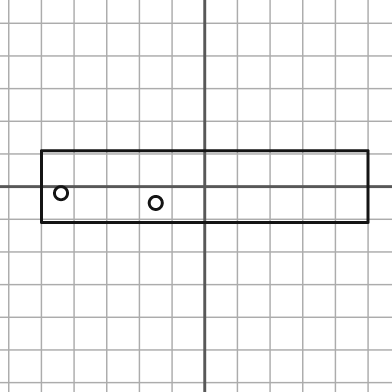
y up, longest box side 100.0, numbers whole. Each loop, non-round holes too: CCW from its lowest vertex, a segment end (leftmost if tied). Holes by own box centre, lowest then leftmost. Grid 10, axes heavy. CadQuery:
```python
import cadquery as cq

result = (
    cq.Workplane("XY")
    .moveTo(-50.0, -11.0)
    .lineTo(50.0, -11.0)
    .lineTo(50.0, 11.0)
    .lineTo(-50.0, 11.0)
    .close()
    .moveTo(-15.0, -5.0)
    .circle(2.0)
    .moveTo(-44.0, -2.0)
    .circle(2.0)
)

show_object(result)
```